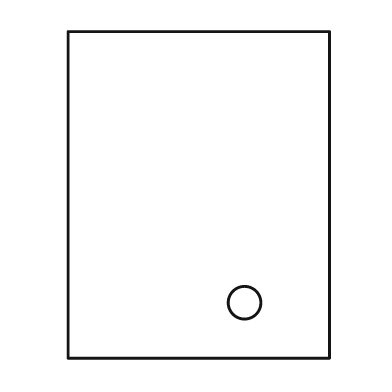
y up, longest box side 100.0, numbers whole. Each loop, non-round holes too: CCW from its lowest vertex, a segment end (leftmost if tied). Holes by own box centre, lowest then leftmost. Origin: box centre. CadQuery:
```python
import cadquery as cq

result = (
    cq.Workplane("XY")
    .moveTo(-40.0, -50.0)
    .lineTo(40.0, -50.0)
    .lineTo(40.0, 50.0)
    .lineTo(-40.0, 50.0)
    .close()
    .moveTo(14.0, -33.0)
    .circle(5.0)
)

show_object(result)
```